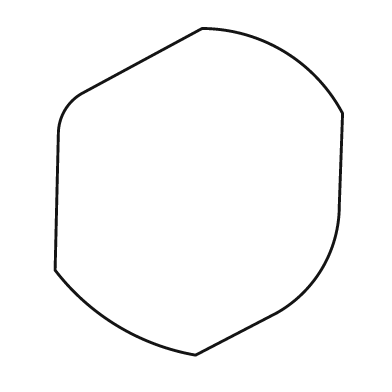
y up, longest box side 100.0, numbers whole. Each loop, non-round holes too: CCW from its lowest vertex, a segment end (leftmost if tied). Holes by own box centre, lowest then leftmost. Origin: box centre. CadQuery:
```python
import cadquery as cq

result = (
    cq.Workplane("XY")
    .moveTo(-1.0, -50.0)
    .lineTo(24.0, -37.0)
    .threePointArc((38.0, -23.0), (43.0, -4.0))
    .lineTo(44.0, 24.0)
    .threePointArc((26.0, 43.0), (1.0, 50.0))
    .lineTo(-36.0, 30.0)
    .threePointArc((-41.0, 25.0), (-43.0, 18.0))
    .lineTo(-44.0, -24.0)
    .threePointArc((-25.0, -41.0), (-1.0, -50.0))
    .close()
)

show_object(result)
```